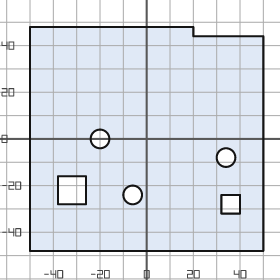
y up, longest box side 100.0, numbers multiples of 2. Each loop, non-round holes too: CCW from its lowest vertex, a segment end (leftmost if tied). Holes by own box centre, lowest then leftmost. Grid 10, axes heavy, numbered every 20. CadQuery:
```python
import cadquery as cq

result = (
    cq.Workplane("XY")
    .moveTo(-50.0, -48.0)
    .lineTo(50.0, -48.0)
    .lineTo(50.0, 44.0)
    .lineTo(20.0, 44.0)
    .lineTo(20.0, 48.0)
    .lineTo(-50.0, 48.0)
    .close()
    .moveTo(32.0, -32.0)
    .lineTo(40.0, -32.0)
    .lineTo(40.0, -24.0)
    .lineTo(32.0, -24.0)
    .close()
    .moveTo(-6.0, -24.0)
    .circle(4.0)
    .moveTo(-38.0, -28.0)
    .lineTo(-26.0, -28.0)
    .lineTo(-26.0, -16.0)
    .lineTo(-38.0, -16.0)
    .close()
    .moveTo(34.0, -8.0)
    .circle(4.0)
    .moveTo(-20.0, 0.0)
    .circle(4.0)
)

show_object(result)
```